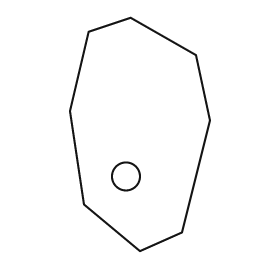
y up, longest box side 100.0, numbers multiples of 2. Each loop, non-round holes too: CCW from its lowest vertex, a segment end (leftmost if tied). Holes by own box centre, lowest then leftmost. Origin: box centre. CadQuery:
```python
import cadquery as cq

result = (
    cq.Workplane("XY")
    .moveTo(0.0, -50.0)
    .lineTo(18.0, -42.0)
    .lineTo(30.0, 6.0)
    .lineTo(24.0, 34.0)
    .lineTo(-4.0, 50.0)
    .lineTo(-22.0, 44.0)
    .lineTo(-30.0, 10.0)
    .lineTo(-24.0, -30.0)
    .close()
    .moveTo(-6.0, -18.0)
    .circle(6.0)
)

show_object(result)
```